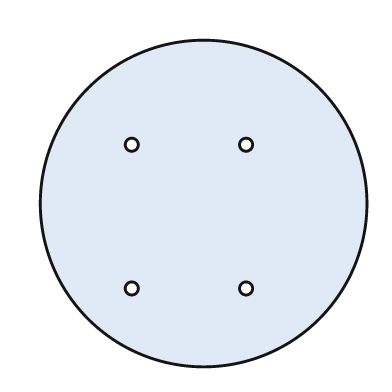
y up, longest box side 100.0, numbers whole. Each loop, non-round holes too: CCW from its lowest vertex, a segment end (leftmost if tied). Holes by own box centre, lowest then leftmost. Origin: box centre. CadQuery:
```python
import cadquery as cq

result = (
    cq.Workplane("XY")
    .moveTo(0.0, 0.0)
    .circle(50.0)
    .moveTo(-22.0, -26.0)
    .circle(2.0)
    .moveTo(13.0, -26.0)
    .circle(2.0)
    .moveTo(-22.0, 18.0)
    .circle(2.0)
    .moveTo(13.0, 18.0)
    .circle(2.0)
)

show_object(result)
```